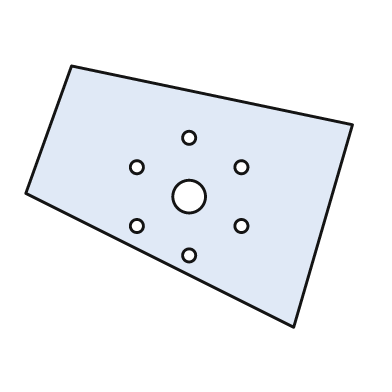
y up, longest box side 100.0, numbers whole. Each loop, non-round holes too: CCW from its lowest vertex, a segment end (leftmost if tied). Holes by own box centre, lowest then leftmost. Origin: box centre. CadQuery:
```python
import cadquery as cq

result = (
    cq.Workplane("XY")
    .moveTo(32.0, -40.0)
    .lineTo(50.0, 22.0)
    .lineTo(-36.0, 40.0)
    .lineTo(-50.0, 1.0)
    .close()
    .moveTo(0.0, -18.0)
    .circle(2.0)
    .moveTo(-16.0, -9.0)
    .circle(2.0)
    .moveTo(16.0, -9.0)
    .circle(2.0)
    .moveTo(0.0, 0.0)
    .circle(5.0)
    .moveTo(-16.0, 9.0)
    .circle(2.0)
    .moveTo(16.0, 9.0)
    .circle(2.0)
    .moveTo(0.0, 18.0)
    .circle(2.0)
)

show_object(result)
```